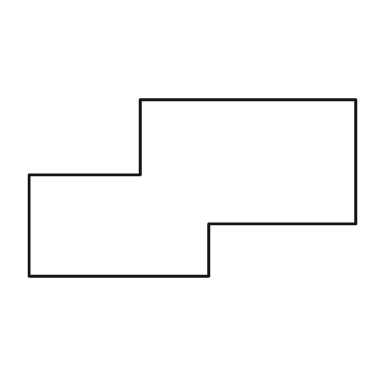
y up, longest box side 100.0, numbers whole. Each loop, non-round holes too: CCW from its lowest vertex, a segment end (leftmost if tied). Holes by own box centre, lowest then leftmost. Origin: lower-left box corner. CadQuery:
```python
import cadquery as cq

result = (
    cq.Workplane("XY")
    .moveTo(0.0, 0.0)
    .lineTo(55.0, 0.0)
    .lineTo(55.0, 16.0)
    .lineTo(100.0, 16.0)
    .lineTo(100.0, 54.0)
    .lineTo(34.0, 54.0)
    .lineTo(34.0, 31.0)
    .lineTo(0.0, 31.0)
    .close()
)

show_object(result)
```